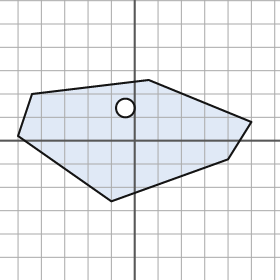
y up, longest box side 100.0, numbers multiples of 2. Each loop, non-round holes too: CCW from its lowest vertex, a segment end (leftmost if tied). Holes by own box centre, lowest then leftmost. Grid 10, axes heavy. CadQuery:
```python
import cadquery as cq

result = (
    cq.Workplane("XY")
    .moveTo(-10.0, -26.0)
    .lineTo(40.0, -8.0)
    .lineTo(50.0, 8.0)
    .lineTo(6.0, 26.0)
    .lineTo(-44.0, 20.0)
    .lineTo(-50.0, 2.0)
    .close()
    .moveTo(-4.0, 14.0)
    .circle(4.0)
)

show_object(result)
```